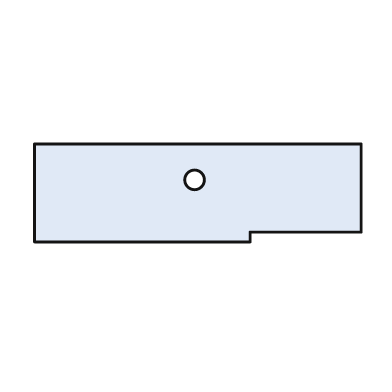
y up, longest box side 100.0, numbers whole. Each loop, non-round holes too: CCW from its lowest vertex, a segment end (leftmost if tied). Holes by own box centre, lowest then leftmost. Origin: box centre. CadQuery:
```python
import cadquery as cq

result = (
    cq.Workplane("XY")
    .moveTo(-50.0, -15.0)
    .lineTo(16.0, -15.0)
    .lineTo(16.0, -12.0)
    .lineTo(50.0, -12.0)
    .lineTo(50.0, 15.0)
    .lineTo(-50.0, 15.0)
    .close()
    .moveTo(-1.0, 4.0)
    .circle(3.0)
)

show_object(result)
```